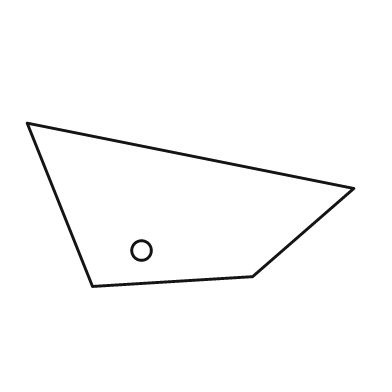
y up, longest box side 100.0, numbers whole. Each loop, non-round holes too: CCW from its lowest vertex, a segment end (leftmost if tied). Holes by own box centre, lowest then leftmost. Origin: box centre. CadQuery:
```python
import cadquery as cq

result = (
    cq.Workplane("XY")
    .moveTo(-30.0, -25.0)
    .lineTo(19.0, -22.0)
    .lineTo(50.0, 5.0)
    .lineTo(-50.0, 25.0)
    .close()
    .moveTo(-15.0, -14.0)
    .circle(3.0)
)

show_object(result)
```